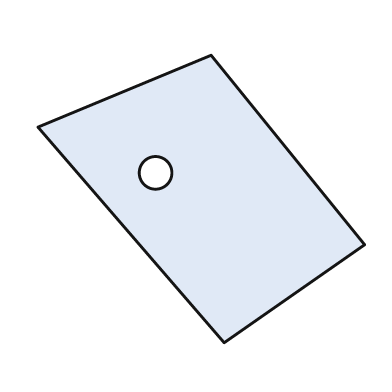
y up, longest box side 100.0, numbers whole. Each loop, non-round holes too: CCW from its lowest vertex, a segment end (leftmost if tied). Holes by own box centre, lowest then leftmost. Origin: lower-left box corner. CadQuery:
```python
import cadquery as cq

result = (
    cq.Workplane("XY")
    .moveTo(57.0, 0.0)
    .lineTo(100.0, 30.0)
    .lineTo(53.0, 88.0)
    .lineTo(0.0, 66.0)
    .close()
    .moveTo(36.0, 52.0)
    .circle(5.0)
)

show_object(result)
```